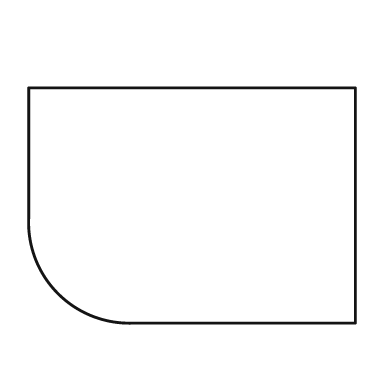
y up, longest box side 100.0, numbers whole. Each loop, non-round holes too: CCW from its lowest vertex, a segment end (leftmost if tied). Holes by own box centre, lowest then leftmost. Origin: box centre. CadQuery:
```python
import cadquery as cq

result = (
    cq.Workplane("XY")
    .moveTo(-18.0, -36.0)
    .lineTo(50.0, -36.0)
    .lineTo(50.0, 36.0)
    .lineTo(-50.0, 36.0)
    .lineTo(-50.0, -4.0)
    .threePointArc((-41.0, -27.0), (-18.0, -36.0))
    .close()
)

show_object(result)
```